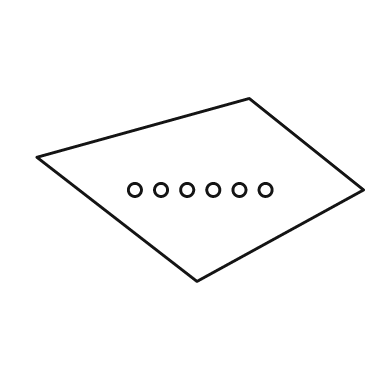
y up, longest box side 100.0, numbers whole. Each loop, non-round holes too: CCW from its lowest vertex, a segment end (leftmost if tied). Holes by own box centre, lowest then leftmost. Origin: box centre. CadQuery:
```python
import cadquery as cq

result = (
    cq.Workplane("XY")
    .moveTo(-1.0, -28.0)
    .lineTo(50.0, 0.0)
    .lineTo(15.0, 28.0)
    .lineTo(-50.0, 10.0)
    .close()
    .moveTo(-20.0, 0.0)
    .circle(2.0)
    .moveTo(-12.0, 0.0)
    .circle(2.0)
    .moveTo(-4.0, 0.0)
    .circle(2.0)
    .moveTo(4.0, 0.0)
    .circle(2.0)
    .moveTo(12.0, 0.0)
    .circle(2.0)
    .moveTo(20.0, 0.0)
    .circle(2.0)
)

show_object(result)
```